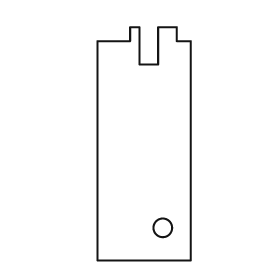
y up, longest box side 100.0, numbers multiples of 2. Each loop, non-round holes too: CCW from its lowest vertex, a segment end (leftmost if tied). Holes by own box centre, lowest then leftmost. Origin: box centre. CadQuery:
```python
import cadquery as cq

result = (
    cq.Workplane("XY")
    .moveTo(-20.0, -50.0)
    .lineTo(20.0, -50.0)
    .lineTo(20.0, 44.0)
    .lineTo(14.0, 44.0)
    .lineTo(14.0, 50.0)
    .lineTo(6.0, 50.0)
    .lineTo(6.0, 34.0)
    .lineTo(-2.0, 34.0)
    .lineTo(-2.0, 50.0)
    .lineTo(-6.0, 50.0)
    .lineTo(-6.0, 44.0)
    .lineTo(-20.0, 44.0)
    .close()
    .moveTo(8.0, -36.0)
    .circle(4.0)
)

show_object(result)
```